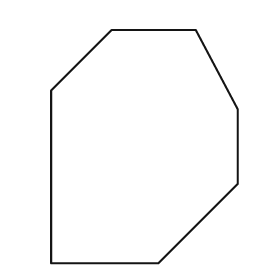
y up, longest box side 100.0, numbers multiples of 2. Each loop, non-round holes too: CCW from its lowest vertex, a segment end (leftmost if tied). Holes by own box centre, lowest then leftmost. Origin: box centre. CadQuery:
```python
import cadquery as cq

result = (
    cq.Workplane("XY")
    .moveTo(-40.0, -50.0)
    .lineTo(6.0, -50.0)
    .lineTo(40.0, -16.0)
    .lineTo(40.0, 16.0)
    .lineTo(22.0, 50.0)
    .lineTo(-14.0, 50.0)
    .lineTo(-40.0, 24.0)
    .close()
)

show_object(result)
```